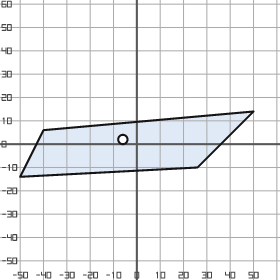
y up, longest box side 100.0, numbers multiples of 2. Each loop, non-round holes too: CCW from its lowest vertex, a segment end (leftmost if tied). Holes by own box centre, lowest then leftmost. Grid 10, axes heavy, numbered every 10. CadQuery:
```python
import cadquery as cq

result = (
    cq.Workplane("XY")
    .moveTo(-50.0, -14.0)
    .lineTo(26.0, -10.0)
    .lineTo(50.0, 14.0)
    .lineTo(-40.0, 6.0)
    .close()
    .moveTo(-6.0, 2.0)
    .circle(2.0)
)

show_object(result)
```